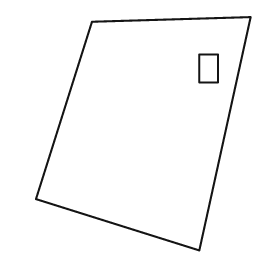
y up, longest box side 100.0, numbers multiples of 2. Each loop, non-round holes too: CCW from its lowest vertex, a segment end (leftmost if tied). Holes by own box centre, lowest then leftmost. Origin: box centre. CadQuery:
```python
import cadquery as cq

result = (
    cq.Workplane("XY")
    .moveTo(24.0, -50.0)
    .lineTo(46.0, 50.0)
    .lineTo(-22.0, 48.0)
    .lineTo(-46.0, -28.0)
    .close()
    .moveTo(24.0, 22.0)
    .lineTo(32.0, 22.0)
    .lineTo(32.0, 34.0)
    .lineTo(24.0, 34.0)
    .close()
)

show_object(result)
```